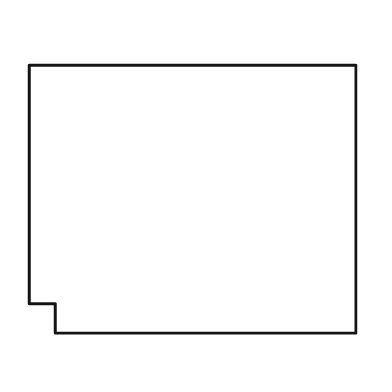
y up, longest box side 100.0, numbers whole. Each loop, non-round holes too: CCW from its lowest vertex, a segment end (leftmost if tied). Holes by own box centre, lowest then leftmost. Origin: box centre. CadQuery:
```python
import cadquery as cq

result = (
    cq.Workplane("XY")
    .moveTo(-42.0, -41.0)
    .lineTo(50.0, -41.0)
    .lineTo(50.0, 41.0)
    .lineTo(-50.0, 41.0)
    .lineTo(-50.0, -32.0)
    .lineTo(-42.0, -32.0)
    .close()
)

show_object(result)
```